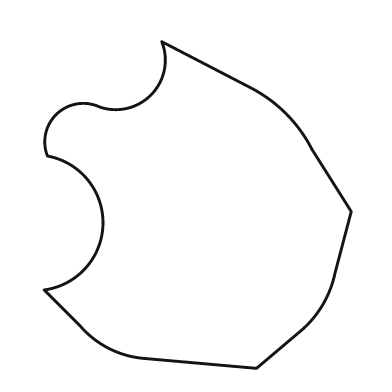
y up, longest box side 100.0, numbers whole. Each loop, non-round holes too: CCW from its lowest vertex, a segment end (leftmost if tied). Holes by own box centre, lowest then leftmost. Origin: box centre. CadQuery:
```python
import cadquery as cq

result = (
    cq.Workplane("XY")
    .moveTo(18.0, -50.0)
    .lineTo(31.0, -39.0)
    .threePointArc((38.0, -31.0), (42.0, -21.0))
    .lineTo(47.0, -2.0)
    .lineTo(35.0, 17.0)
    .threePointArc((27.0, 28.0), (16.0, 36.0))
    .lineTo(-11.0, 50.0)
    .threePointArc((-14.0, 34.0), (-30.0, 30.0))
    .threePointArc((-43.0, 28.0), (-46.0, 15.0))
    .threePointArc((-29.0, -6.0), (-47.0, -26.0))
    .lineTo(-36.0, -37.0)
    .threePointArc((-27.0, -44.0), (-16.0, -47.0))
    .close()
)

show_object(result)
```